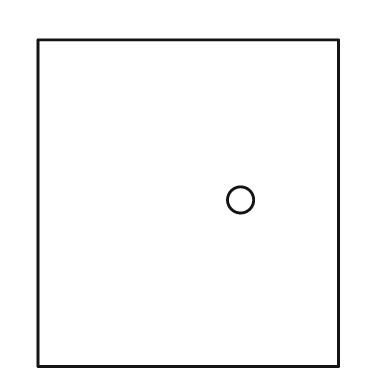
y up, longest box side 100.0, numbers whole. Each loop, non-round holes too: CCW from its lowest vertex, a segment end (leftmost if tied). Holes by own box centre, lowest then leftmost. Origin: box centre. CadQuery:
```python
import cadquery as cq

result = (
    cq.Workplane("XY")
    .moveTo(-46.0, -50.0)
    .lineTo(46.0, -50.0)
    .lineTo(46.0, 50.0)
    .lineTo(-46.0, 50.0)
    .close()
    .moveTo(16.0, 1.0)
    .circle(4.0)
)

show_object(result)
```